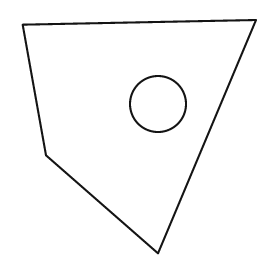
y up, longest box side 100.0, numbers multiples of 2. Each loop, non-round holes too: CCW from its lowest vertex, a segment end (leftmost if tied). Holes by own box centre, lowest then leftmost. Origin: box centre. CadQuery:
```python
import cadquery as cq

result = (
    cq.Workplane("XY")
    .moveTo(8.0, -50.0)
    .lineTo(50.0, 50.0)
    .lineTo(-50.0, 48.0)
    .lineTo(-40.0, -8.0)
    .close()
    .moveTo(8.0, 14.0)
    .circle(12.0)
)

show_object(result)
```